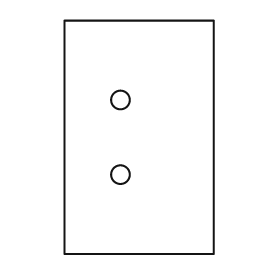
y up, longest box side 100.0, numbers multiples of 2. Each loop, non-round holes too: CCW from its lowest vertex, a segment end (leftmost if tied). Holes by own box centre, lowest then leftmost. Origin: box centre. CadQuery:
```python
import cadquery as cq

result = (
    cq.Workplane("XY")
    .moveTo(-32.0, -50.0)
    .lineTo(32.0, -50.0)
    .lineTo(32.0, 50.0)
    .lineTo(-32.0, 50.0)
    .close()
    .moveTo(-8.0, -16.0)
    .circle(4.0)
    .moveTo(-8.0, 16.0)
    .circle(4.0)
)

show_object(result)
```